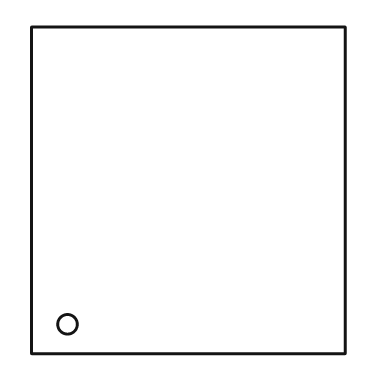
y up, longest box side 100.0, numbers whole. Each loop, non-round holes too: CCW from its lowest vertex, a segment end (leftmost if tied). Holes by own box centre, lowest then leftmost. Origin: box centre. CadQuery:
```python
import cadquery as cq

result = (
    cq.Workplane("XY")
    .moveTo(-48.0, -50.0)
    .lineTo(48.0, -50.0)
    .lineTo(48.0, 50.0)
    .lineTo(-48.0, 50.0)
    .close()
    .moveTo(-37.0, -41.0)
    .circle(3.0)
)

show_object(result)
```